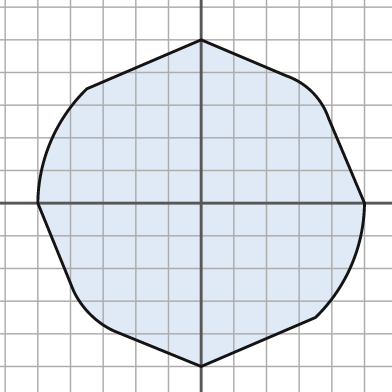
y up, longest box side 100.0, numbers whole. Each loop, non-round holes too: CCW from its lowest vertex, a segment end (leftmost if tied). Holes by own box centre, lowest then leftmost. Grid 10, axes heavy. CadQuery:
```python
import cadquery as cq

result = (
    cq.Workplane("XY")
    .moveTo(0.0, -50.0)
    .lineTo(35.0, -35.0)
    .threePointArc((46.0, -19.0), (50.0, 0.0))
    .lineTo(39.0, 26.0)
    .threePointArc((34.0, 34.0), (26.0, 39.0))
    .lineTo(0.0, 50.0)
    .lineTo(-35.0, 35.0)
    .threePointArc((-46.0, 19.0), (-50.0, 0.0))
    .lineTo(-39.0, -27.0)
    .threePointArc((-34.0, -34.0), (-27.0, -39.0))
    .close()
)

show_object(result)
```